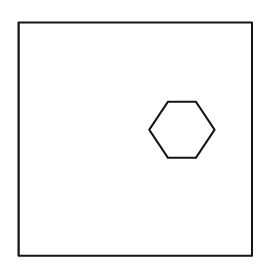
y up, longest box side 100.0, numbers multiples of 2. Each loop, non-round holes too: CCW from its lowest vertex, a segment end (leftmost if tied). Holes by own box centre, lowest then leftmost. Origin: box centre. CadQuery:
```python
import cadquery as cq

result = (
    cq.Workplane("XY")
    .moveTo(-50.0, -50.0)
    .lineTo(50.0, -50.0)
    .lineTo(50.0, 50.0)
    .lineTo(-50.0, 50.0)
    .close()
    .moveTo(14.0, -8.0)
    .lineTo(26.0, -8.0)
    .lineTo(34.0, 4.0)
    .lineTo(26.0, 16.0)
    .lineTo(14.0, 16.0)
    .lineTo(6.0, 4.0)
    .close()
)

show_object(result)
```